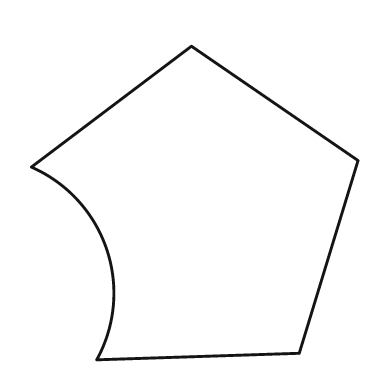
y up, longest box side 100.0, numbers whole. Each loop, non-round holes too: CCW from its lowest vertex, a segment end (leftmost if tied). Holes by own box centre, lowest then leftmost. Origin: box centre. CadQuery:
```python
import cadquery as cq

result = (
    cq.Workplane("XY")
    .moveTo(-30.0, -48.0)
    .lineTo(32.0, -46.0)
    .lineTo(50.0, 13.0)
    .lineTo(-1.0, 48.0)
    .lineTo(-50.0, 11.0)
    .threePointArc((-27.0, -14.0), (-30.0, -48.0))
    .close()
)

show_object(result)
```